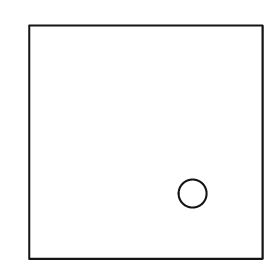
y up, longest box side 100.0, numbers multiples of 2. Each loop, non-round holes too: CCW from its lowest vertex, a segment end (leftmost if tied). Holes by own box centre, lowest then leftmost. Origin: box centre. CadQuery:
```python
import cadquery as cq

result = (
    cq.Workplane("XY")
    .moveTo(-50.0, -50.0)
    .lineTo(50.0, -50.0)
    .lineTo(50.0, 50.0)
    .lineTo(-50.0, 50.0)
    .close()
    .moveTo(20.0, -22.0)
    .circle(6.0)
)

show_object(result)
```